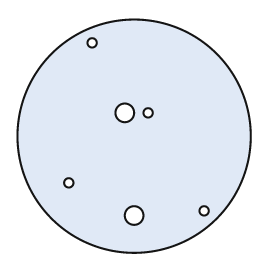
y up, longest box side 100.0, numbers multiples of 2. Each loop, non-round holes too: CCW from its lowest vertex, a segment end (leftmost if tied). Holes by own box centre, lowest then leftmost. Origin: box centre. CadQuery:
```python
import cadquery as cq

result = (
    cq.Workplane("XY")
    .moveTo(0.0, 0.0)
    .circle(50.0)
    .moveTo(0.0, -34.0)
    .circle(4.0)
    .moveTo(30.0, -32.0)
    .circle(2.0)
    .moveTo(-28.0, -20.0)
    .circle(2.0)
    .moveTo(-4.0, 10.0)
    .circle(4.0)
    .moveTo(6.0, 10.0)
    .circle(2.0)
    .moveTo(-18.0, 40.0)
    .circle(2.0)
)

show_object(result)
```